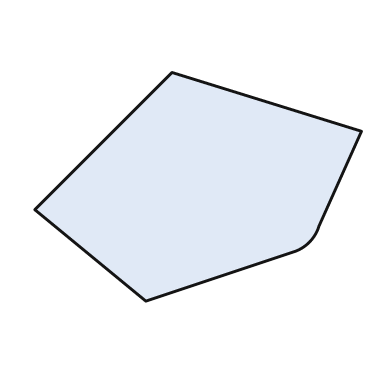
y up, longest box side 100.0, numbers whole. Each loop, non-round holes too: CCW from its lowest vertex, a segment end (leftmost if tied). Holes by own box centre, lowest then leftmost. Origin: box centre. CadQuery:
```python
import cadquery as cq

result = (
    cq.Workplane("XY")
    .moveTo(-16.0, -35.0)
    .lineTo(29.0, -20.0)
    .threePointArc((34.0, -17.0), (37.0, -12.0))
    .lineTo(50.0, 17.0)
    .lineTo(-8.0, 35.0)
    .lineTo(-50.0, -7.0)
    .close()
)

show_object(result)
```